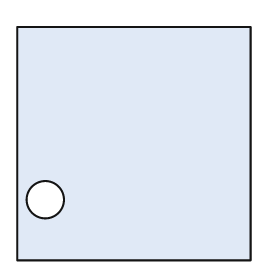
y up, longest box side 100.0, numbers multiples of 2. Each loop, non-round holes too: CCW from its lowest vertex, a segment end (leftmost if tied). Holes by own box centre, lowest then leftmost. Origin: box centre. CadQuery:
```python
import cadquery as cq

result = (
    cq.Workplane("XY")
    .moveTo(-50.0, -50.0)
    .lineTo(50.0, -50.0)
    .lineTo(50.0, 50.0)
    .lineTo(-50.0, 50.0)
    .close()
    .moveTo(-38.0, -24.0)
    .circle(8.0)
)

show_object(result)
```